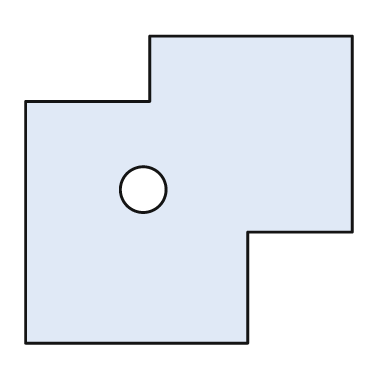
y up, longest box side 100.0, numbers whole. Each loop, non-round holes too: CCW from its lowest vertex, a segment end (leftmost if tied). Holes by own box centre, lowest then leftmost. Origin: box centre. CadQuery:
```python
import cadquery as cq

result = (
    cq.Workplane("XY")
    .moveTo(-50.0, -47.0)
    .lineTo(18.0, -47.0)
    .lineTo(18.0, -13.0)
    .lineTo(50.0, -13.0)
    .lineTo(50.0, 47.0)
    .lineTo(-12.0, 47.0)
    .lineTo(-12.0, 27.0)
    .lineTo(-50.0, 27.0)
    .close()
    .moveTo(-14.0, 0.0)
    .circle(7.0)
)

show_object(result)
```